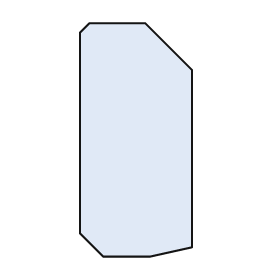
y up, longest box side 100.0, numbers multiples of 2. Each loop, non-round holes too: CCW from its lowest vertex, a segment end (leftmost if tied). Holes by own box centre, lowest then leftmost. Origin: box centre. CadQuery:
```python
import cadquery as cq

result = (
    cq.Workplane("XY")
    .moveTo(-14.0, -50.0)
    .lineTo(6.0, -50.0)
    .lineTo(24.0, -46.0)
    .lineTo(24.0, 30.0)
    .lineTo(4.0, 50.0)
    .lineTo(-20.0, 50.0)
    .lineTo(-24.0, 46.0)
    .lineTo(-24.0, -40.0)
    .close()
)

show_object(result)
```